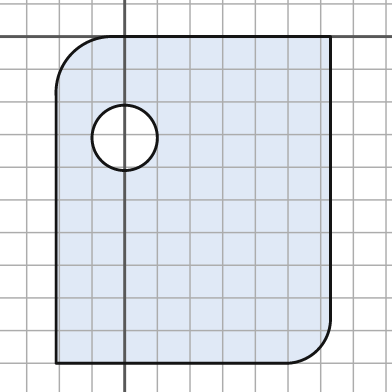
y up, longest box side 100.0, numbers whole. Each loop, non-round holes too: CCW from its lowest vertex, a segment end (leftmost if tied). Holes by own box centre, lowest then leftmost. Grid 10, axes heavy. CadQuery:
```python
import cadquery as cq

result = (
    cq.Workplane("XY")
    .moveTo(-21.0, -100.0)
    .lineTo(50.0, -100.0)
    .threePointArc((59.0, -96.0), (63.0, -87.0))
    .lineTo(63.0, 0.0)
    .lineTo(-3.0, 0.0)
    .threePointArc((-16.0, -5.0), (-21.0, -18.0))
    .close()
    .moveTo(0.0, -31.0)
    .circle(10.0)
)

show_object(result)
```